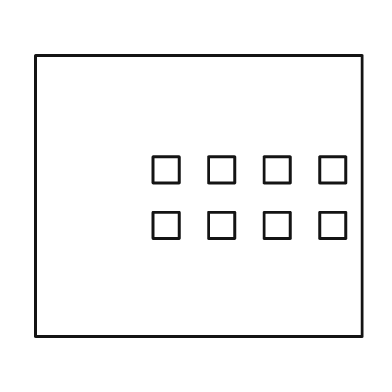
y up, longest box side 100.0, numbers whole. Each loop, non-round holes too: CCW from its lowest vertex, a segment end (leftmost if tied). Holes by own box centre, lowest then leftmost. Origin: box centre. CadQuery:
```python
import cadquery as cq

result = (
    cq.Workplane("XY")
    .moveTo(-50.0, -43.0)
    .lineTo(50.0, -43.0)
    .lineTo(50.0, 43.0)
    .lineTo(-50.0, 43.0)
    .close()
    .moveTo(-14.0, -13.0)
    .lineTo(-6.0, -13.0)
    .lineTo(-6.0, -5.0)
    .lineTo(-14.0, -5.0)
    .close()
    .moveTo(3.0, -13.0)
    .lineTo(11.0, -13.0)
    .lineTo(11.0, -5.0)
    .lineTo(3.0, -5.0)
    .close()
    .moveTo(20.0, -13.0)
    .lineTo(28.0, -13.0)
    .lineTo(28.0, -5.0)
    .lineTo(20.0, -5.0)
    .close()
    .moveTo(37.0, -13.0)
    .lineTo(45.0, -13.0)
    .lineTo(45.0, -5.0)
    .lineTo(37.0, -5.0)
    .close()
    .moveTo(-14.0, 4.0)
    .lineTo(-6.0, 4.0)
    .lineTo(-6.0, 12.0)
    .lineTo(-14.0, 12.0)
    .close()
    .moveTo(3.0, 4.0)
    .lineTo(11.0, 4.0)
    .lineTo(11.0, 12.0)
    .lineTo(3.0, 12.0)
    .close()
    .moveTo(20.0, 4.0)
    .lineTo(28.0, 4.0)
    .lineTo(28.0, 12.0)
    .lineTo(20.0, 12.0)
    .close()
    .moveTo(37.0, 4.0)
    .lineTo(45.0, 4.0)
    .lineTo(45.0, 12.0)
    .lineTo(37.0, 12.0)
    .close()
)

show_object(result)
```